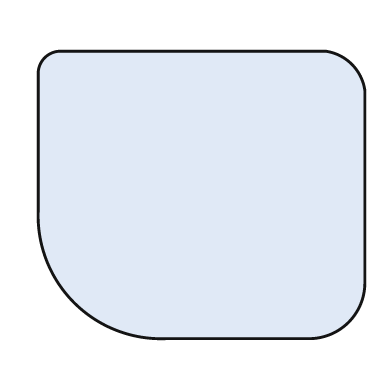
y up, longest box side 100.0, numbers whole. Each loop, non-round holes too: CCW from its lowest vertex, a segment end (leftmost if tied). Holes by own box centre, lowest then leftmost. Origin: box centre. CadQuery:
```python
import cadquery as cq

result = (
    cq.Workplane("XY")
    .moveTo(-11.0, -44.0)
    .lineTo(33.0, -44.0)
    .threePointArc((45.0, -39.0), (50.0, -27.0))
    .lineTo(50.0, 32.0)
    .threePointArc((46.0, 40.0), (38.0, 44.0))
    .lineTo(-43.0, 44.0)
    .threePointArc((-48.0, 42.0), (-50.0, 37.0))
    .lineTo(-50.0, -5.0)
    .threePointArc((-39.0, -33.0), (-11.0, -44.0))
    .close()
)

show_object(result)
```